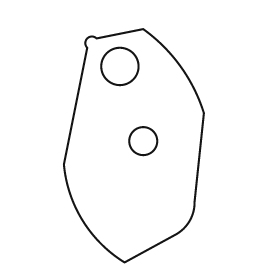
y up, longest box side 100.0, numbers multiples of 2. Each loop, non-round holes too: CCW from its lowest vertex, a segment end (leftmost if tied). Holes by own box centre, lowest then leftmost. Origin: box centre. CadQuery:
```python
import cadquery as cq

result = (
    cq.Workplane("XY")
    .moveTo(-4.0, -50.0)
    .lineTo(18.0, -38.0)
    .threePointArc((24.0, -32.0), (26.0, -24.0))
    .lineTo(30.0, 14.0)
    .threePointArc((20.0, 34.0), (4.0, 50.0))
    .lineTo(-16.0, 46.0)
    .threePointArc((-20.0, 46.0), (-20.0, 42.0))
    .lineTo(-30.0, -8.0)
    .threePointArc((-22.0, -32.0), (-4.0, -50.0))
    .close()
    .moveTo(4.0, 2.0)
    .circle(6.0)
    .moveTo(-6.0, 34.0)
    .circle(8.0)
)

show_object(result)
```